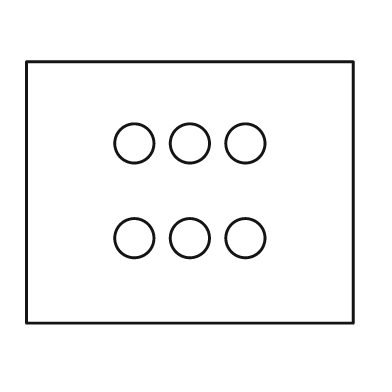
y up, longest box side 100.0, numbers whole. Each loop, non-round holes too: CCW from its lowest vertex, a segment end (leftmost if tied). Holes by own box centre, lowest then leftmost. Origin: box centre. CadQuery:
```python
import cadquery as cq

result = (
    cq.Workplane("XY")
    .moveTo(-50.0, -40.0)
    .lineTo(50.0, -40.0)
    .lineTo(50.0, 40.0)
    .lineTo(-50.0, 40.0)
    .close()
    .moveTo(-17.0, -14.0)
    .circle(6.0)
    .moveTo(0.0, -14.0)
    .circle(6.0)
    .moveTo(17.0, -14.0)
    .circle(6.0)
    .moveTo(-17.0, 15.0)
    .circle(6.0)
    .moveTo(0.0, 15.0)
    .circle(6.0)
    .moveTo(17.0, 15.0)
    .circle(6.0)
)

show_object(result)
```